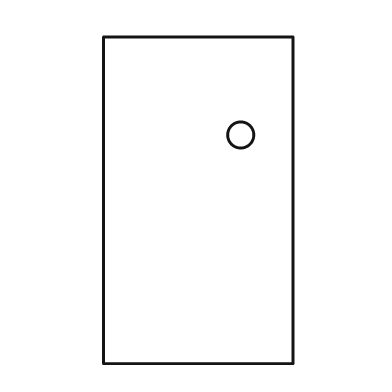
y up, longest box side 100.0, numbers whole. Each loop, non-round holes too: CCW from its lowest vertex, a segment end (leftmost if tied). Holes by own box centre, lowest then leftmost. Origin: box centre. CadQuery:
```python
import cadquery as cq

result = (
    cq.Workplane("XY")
    .moveTo(-29.0, -50.0)
    .lineTo(29.0, -50.0)
    .lineTo(29.0, 50.0)
    .lineTo(-29.0, 50.0)
    .close()
    .moveTo(13.0, 20.0)
    .circle(4.0)
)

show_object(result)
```